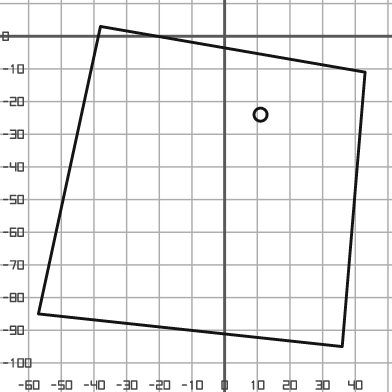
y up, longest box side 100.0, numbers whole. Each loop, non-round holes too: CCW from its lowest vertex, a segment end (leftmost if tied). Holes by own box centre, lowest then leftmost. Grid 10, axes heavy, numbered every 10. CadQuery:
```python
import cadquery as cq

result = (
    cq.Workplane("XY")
    .moveTo(36.0, -95.0)
    .lineTo(43.0, -11.0)
    .lineTo(-38.0, 3.0)
    .lineTo(-57.0, -85.0)
    .close()
    .moveTo(11.0, -24.0)
    .circle(2.0)
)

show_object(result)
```